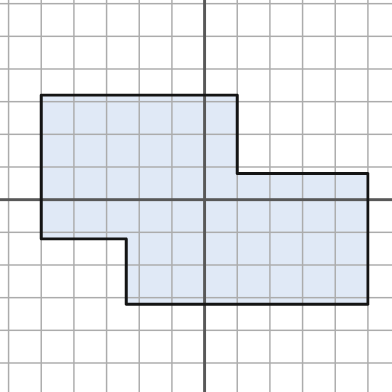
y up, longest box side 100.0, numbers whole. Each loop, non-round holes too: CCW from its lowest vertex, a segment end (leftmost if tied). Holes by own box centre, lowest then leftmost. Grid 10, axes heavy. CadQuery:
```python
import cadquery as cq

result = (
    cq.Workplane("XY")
    .moveTo(-24.0, -32.0)
    .lineTo(50.0, -32.0)
    .lineTo(50.0, 8.0)
    .lineTo(10.0, 8.0)
    .lineTo(10.0, 32.0)
    .lineTo(-50.0, 32.0)
    .lineTo(-50.0, -12.0)
    .lineTo(-24.0, -12.0)
    .close()
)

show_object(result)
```